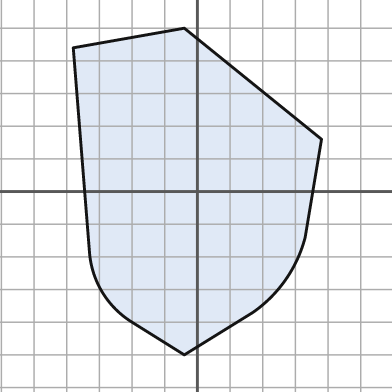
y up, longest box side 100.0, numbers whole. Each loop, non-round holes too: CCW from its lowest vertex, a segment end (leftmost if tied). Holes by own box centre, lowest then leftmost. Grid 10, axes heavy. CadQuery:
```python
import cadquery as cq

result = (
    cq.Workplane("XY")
    .moveTo(-4.0, -50.0)
    .lineTo(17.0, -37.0)
    .threePointArc((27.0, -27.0), (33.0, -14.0))
    .lineTo(38.0, 16.0)
    .lineTo(-4.0, 50.0)
    .lineTo(-38.0, 44.0)
    .lineTo(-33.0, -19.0)
    .threePointArc((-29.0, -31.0), (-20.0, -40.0))
    .close()
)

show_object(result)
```